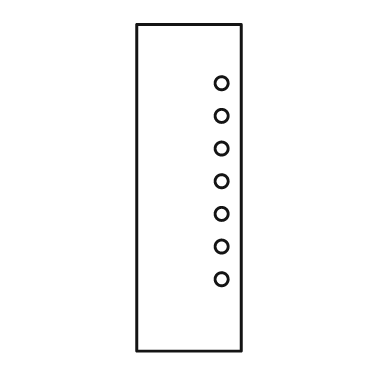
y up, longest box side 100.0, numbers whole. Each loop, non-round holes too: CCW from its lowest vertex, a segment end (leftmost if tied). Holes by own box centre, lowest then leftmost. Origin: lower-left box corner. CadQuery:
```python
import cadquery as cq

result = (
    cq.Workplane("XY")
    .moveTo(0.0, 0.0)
    .lineTo(32.0, 0.0)
    .lineTo(32.0, 100.0)
    .lineTo(0.0, 100.0)
    .close()
    .moveTo(26.0, 22.0)
    .circle(2.0)
    .moveTo(26.0, 32.0)
    .circle(2.0)
    .moveTo(26.0, 42.0)
    .circle(2.0)
    .moveTo(26.0, 52.0)
    .circle(2.0)
    .moveTo(26.0, 62.0)
    .circle(2.0)
    .moveTo(26.0, 72.0)
    .circle(2.0)
    .moveTo(26.0, 82.0)
    .circle(2.0)
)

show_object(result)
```